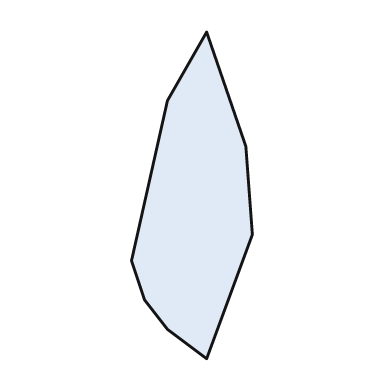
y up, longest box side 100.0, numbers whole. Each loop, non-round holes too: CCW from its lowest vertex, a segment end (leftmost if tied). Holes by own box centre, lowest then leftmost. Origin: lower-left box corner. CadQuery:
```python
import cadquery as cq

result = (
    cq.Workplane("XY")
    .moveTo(23.0, 0.0)
    .lineTo(37.0, 38.0)
    .lineTo(35.0, 65.0)
    .lineTo(23.0, 100.0)
    .lineTo(11.0, 79.0)
    .lineTo(0.0, 30.0)
    .lineTo(4.0, 18.0)
    .lineTo(11.0, 9.0)
    .close()
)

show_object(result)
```